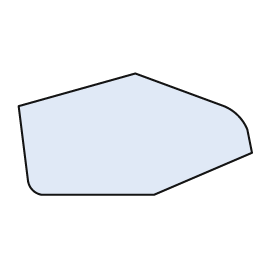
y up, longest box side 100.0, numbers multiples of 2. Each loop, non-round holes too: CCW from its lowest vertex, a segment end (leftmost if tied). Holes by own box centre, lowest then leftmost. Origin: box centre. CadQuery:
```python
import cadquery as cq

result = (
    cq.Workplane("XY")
    .moveTo(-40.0, -26.0)
    .lineTo(8.0, -26.0)
    .lineTo(50.0, -8.0)
    .lineTo(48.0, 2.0)
    .threePointArc((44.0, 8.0), (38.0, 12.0))
    .lineTo(0.0, 26.0)
    .lineTo(-50.0, 12.0)
    .lineTo(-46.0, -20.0)
    .threePointArc((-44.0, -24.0), (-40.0, -26.0))
    .close()
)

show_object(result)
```